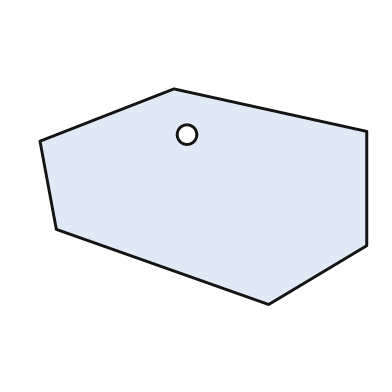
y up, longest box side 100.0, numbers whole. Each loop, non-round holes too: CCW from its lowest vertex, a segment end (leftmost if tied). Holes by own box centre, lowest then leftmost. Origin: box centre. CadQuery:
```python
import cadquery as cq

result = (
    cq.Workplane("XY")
    .moveTo(20.0, -33.0)
    .lineTo(50.0, -15.0)
    .lineTo(50.0, 20.0)
    .lineTo(-9.0, 33.0)
    .lineTo(-50.0, 17.0)
    .lineTo(-45.0, -10.0)
    .close()
    .moveTo(-5.0, 19.0)
    .circle(3.0)
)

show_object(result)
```